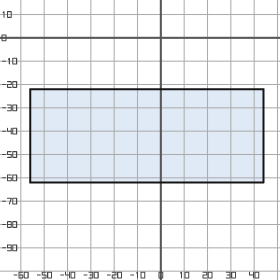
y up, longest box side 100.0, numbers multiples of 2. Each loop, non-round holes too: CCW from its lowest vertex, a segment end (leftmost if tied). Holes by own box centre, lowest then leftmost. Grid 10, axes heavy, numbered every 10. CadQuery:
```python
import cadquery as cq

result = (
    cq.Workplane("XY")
    .moveTo(-56.0, -62.0)
    .lineTo(44.0, -62.0)
    .lineTo(44.0, -22.0)
    .lineTo(-56.0, -22.0)
    .close()
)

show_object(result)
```